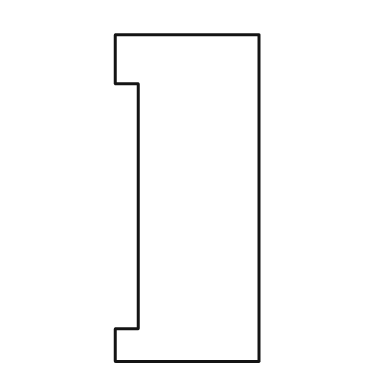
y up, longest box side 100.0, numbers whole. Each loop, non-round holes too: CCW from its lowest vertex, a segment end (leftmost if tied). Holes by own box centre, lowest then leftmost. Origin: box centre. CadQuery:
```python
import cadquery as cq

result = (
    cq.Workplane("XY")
    .moveTo(-22.0, -50.0)
    .lineTo(22.0, -50.0)
    .lineTo(22.0, 50.0)
    .lineTo(-22.0, 50.0)
    .lineTo(-22.0, 35.0)
    .lineTo(-15.0, 35.0)
    .lineTo(-15.0, -40.0)
    .lineTo(-22.0, -40.0)
    .close()
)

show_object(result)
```